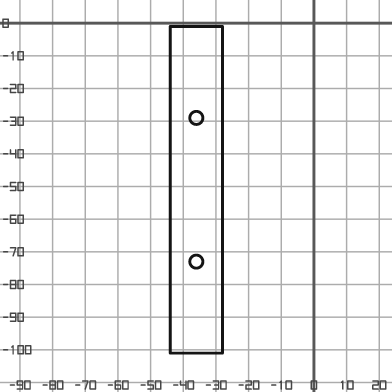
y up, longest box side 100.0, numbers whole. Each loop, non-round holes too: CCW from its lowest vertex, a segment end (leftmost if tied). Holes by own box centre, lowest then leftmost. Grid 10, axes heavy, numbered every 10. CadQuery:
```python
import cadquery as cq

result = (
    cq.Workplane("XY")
    .moveTo(-44.0, -101.0)
    .lineTo(-28.0, -101.0)
    .lineTo(-28.0, -1.0)
    .lineTo(-44.0, -1.0)
    .close()
    .moveTo(-36.0, -73.0)
    .circle(2.0)
    .moveTo(-36.0, -29.0)
    .circle(2.0)
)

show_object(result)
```